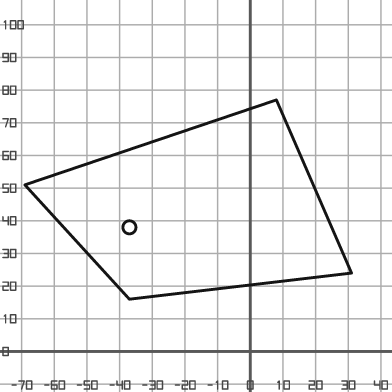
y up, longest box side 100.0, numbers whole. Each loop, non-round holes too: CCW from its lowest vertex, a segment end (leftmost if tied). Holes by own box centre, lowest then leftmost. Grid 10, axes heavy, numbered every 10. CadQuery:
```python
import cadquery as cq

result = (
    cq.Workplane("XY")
    .moveTo(-37.0, 16.0)
    .lineTo(31.0, 24.0)
    .lineTo(8.0, 77.0)
    .lineTo(-69.0, 51.0)
    .close()
    .moveTo(-37.0, 38.0)
    .circle(2.0)
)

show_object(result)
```